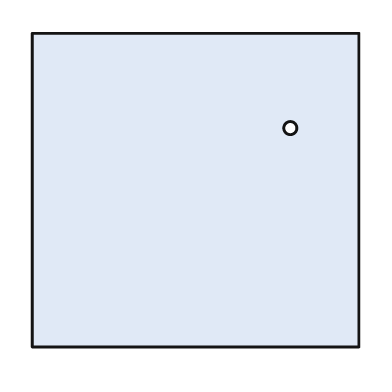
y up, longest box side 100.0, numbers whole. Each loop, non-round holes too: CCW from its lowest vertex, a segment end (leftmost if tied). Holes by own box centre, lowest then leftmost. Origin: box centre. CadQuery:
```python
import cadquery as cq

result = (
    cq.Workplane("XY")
    .moveTo(-50.0, -48.0)
    .lineTo(50.0, -48.0)
    .lineTo(50.0, 48.0)
    .lineTo(-50.0, 48.0)
    .close()
    .moveTo(29.0, 19.0)
    .circle(2.0)
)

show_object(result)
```